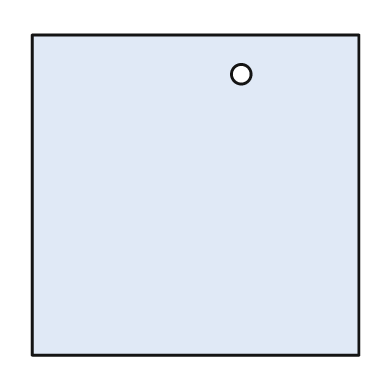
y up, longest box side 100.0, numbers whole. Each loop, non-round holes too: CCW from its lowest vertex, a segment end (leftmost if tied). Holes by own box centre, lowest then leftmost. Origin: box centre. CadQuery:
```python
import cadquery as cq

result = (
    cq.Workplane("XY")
    .moveTo(-50.0, -49.0)
    .lineTo(50.0, -49.0)
    .lineTo(50.0, 49.0)
    .lineTo(-50.0, 49.0)
    .close()
    .moveTo(14.0, 37.0)
    .circle(3.0)
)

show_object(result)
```